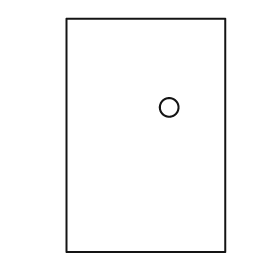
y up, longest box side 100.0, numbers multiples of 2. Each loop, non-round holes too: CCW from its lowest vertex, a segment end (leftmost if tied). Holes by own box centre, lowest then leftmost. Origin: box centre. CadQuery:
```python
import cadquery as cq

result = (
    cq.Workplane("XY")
    .moveTo(-34.0, -50.0)
    .lineTo(34.0, -50.0)
    .lineTo(34.0, 50.0)
    .lineTo(-34.0, 50.0)
    .close()
    .moveTo(10.0, 12.0)
    .circle(4.0)
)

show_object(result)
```